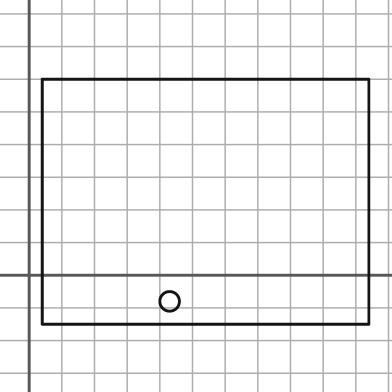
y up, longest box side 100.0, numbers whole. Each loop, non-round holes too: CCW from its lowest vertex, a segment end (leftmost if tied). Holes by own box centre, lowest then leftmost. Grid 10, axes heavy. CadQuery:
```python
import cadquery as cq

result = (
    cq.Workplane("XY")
    .moveTo(4.0, -15.0)
    .lineTo(104.0, -15.0)
    .lineTo(104.0, 60.0)
    .lineTo(4.0, 60.0)
    .close()
    .moveTo(43.0, -8.0)
    .circle(3.0)
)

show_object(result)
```